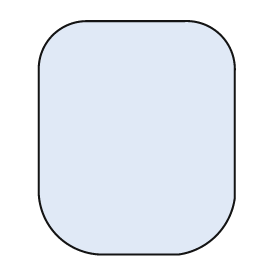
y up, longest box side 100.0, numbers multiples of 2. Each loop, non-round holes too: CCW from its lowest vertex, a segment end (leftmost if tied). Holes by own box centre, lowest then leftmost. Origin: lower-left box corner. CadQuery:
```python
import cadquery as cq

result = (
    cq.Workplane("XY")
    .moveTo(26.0, 0.0)
    .lineTo(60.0, 0.0)
    .threePointArc((76.0, 8.0), (84.0, 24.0))
    .lineTo(84.0, 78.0)
    .threePointArc((78.0, 94.0), (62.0, 100.0))
    .lineTo(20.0, 100.0)
    .threePointArc((6.0, 94.0), (0.0, 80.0))
    .lineTo(0.0, 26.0)
    .threePointArc((8.0, 8.0), (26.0, 0.0))
    .close()
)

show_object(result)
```